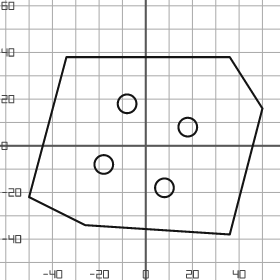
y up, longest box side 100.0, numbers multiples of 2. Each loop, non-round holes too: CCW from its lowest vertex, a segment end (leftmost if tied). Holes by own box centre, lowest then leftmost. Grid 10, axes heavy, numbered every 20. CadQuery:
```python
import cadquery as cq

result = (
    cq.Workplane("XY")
    .moveTo(36.0, -38.0)
    .lineTo(50.0, 16.0)
    .lineTo(36.0, 38.0)
    .lineTo(-34.0, 38.0)
    .lineTo(-50.0, -22.0)
    .lineTo(-26.0, -34.0)
    .close()
    .moveTo(8.0, -18.0)
    .circle(4.0)
    .moveTo(-18.0, -8.0)
    .circle(4.0)
    .moveTo(18.0, 8.0)
    .circle(4.0)
    .moveTo(-8.0, 18.0)
    .circle(4.0)
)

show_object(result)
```